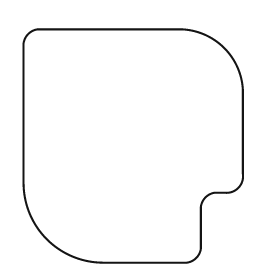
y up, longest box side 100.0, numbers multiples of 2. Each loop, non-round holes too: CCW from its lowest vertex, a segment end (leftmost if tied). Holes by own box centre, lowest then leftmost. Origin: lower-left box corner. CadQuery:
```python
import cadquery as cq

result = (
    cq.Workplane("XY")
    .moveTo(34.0, 0.0)
    .lineTo(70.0, 0.0)
    .threePointArc((74.0, 2.0), (76.0, 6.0))
    .lineTo(76.0, 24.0)
    .threePointArc((78.0, 28.0), (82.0, 30.0))
    .lineTo(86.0, 30.0)
    .threePointArc((92.0, 32.0), (94.0, 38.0))
    .lineTo(94.0, 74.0)
    .threePointArc((86.0, 92.0), (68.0, 100.0))
    .lineTo(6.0, 100.0)
    .threePointArc((2.0, 98.0), (0.0, 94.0))
    .lineTo(0.0, 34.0)
    .threePointArc((10.0, 10.0), (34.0, 0.0))
    .close()
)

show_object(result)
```